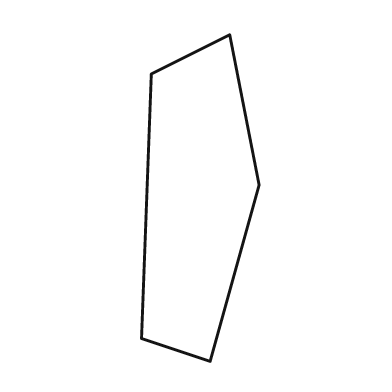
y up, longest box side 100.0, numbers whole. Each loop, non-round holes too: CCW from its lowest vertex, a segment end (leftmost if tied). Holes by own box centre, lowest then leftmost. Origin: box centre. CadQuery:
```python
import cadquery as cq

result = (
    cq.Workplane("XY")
    .moveTo(3.0, -50.0)
    .lineTo(18.0, 4.0)
    .lineTo(9.0, 50.0)
    .lineTo(-15.0, 38.0)
    .lineTo(-18.0, -43.0)
    .close()
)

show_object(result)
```